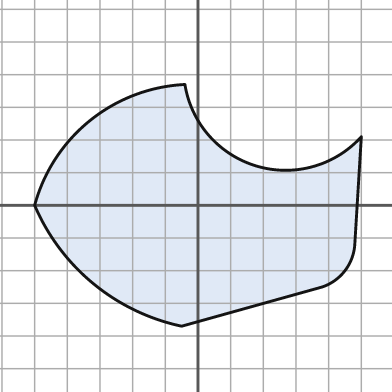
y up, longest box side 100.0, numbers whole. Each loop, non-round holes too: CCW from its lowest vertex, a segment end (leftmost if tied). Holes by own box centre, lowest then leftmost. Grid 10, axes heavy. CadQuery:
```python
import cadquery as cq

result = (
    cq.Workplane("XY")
    .moveTo(-5.0, -37.0)
    .lineTo(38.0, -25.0)
    .threePointArc((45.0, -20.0), (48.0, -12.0))
    .lineTo(50.0, 21.0)
    .threePointArc((18.0, 12.0), (-4.0, 37.0))
    .threePointArc((-33.0, 26.0), (-50.0, 0.0))
    .threePointArc((-32.0, -24.0), (-5.0, -37.0))
    .close()
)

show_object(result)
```